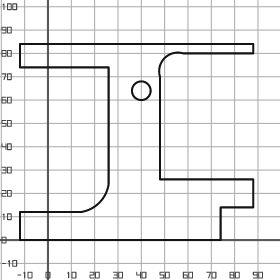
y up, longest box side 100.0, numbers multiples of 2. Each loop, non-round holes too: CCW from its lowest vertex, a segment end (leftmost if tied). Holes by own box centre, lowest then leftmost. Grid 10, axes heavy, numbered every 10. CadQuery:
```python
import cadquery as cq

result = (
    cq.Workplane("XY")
    .moveTo(-12.0, 0.0)
    .lineTo(74.0, 0.0)
    .lineTo(74.0, 14.0)
    .lineTo(88.0, 14.0)
    .lineTo(88.0, 26.0)
    .lineTo(48.0, 26.0)
    .lineTo(48.0, 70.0)
    .threePointArc((50.0, 78.0), (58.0, 80.0))
    .lineTo(88.0, 80.0)
    .lineTo(88.0, 84.0)
    .lineTo(-12.0, 84.0)
    .lineTo(-12.0, 74.0)
    .lineTo(26.0, 74.0)
    .lineTo(26.0, 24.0)
    .threePointArc((22.0, 16.0), (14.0, 12.0))
    .lineTo(-12.0, 12.0)
    .close()
    .moveTo(40.0, 64.0)
    .circle(4.0)
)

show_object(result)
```